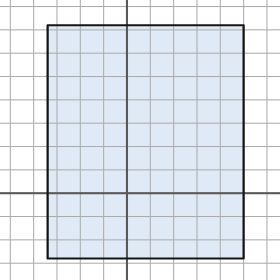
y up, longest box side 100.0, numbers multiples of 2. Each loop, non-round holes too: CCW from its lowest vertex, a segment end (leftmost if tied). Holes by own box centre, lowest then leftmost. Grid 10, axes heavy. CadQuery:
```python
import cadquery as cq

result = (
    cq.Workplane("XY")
    .moveTo(-34.0, -28.0)
    .lineTo(50.0, -28.0)
    .lineTo(50.0, 72.0)
    .lineTo(-34.0, 72.0)
    .close()
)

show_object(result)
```